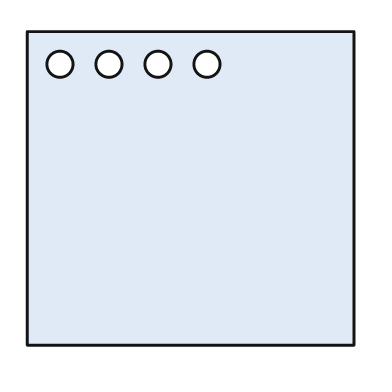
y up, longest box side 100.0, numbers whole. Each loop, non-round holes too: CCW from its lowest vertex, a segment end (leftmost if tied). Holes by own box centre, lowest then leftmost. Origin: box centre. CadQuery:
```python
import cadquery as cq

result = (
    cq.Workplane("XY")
    .moveTo(-50.0, -48.0)
    .lineTo(50.0, -48.0)
    .lineTo(50.0, 48.0)
    .lineTo(-50.0, 48.0)
    .close()
    .moveTo(-40.0, 38.0)
    .circle(4.0)
    .moveTo(-25.0, 38.0)
    .circle(4.0)
    .moveTo(-10.0, 38.0)
    .circle(4.0)
    .moveTo(5.0, 38.0)
    .circle(4.0)
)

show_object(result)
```